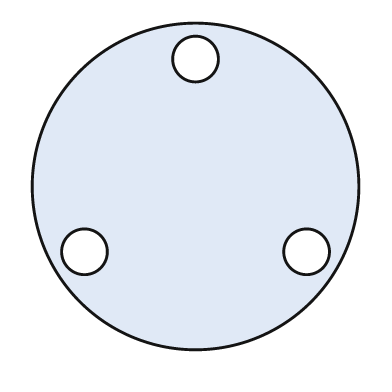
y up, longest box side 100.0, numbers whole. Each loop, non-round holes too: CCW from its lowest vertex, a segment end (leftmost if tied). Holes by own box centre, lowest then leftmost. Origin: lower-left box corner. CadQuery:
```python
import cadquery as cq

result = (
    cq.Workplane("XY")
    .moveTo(50.0, 50.0)
    .circle(50.0)
    .moveTo(16.0, 30.0)
    .circle(7.0)
    .moveTo(84.0, 30.0)
    .circle(7.0)
    .moveTo(50.0, 89.0)
    .circle(7.0)
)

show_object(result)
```